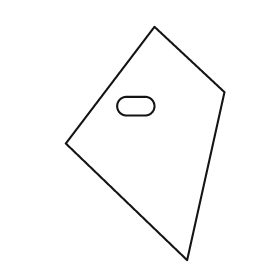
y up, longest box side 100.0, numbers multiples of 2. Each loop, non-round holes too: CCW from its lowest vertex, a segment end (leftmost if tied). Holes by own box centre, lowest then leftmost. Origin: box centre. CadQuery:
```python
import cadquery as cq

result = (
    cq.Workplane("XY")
    .moveTo(18.0, -50.0)
    .lineTo(34.0, 22.0)
    .lineTo(4.0, 50.0)
    .lineTo(-34.0, 0.0)
    .close()
    .moveTo(-8.0, 12.0)
    .lineTo(0.0, 12.0)
    .threePointArc((4.0, 16.0), (0.0, 20.0))
    .lineTo(-8.0, 20.0)
    .threePointArc((-12.0, 16.0), (-8.0, 12.0))
    .close()
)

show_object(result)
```